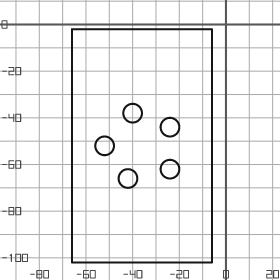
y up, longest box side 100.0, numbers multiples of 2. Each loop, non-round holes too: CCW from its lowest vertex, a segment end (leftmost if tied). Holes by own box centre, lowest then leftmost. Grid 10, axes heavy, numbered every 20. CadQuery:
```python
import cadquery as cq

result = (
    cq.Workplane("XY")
    .moveTo(-66.0, -102.0)
    .lineTo(-6.0, -102.0)
    .lineTo(-6.0, -2.0)
    .lineTo(-66.0, -2.0)
    .close()
    .moveTo(-42.0, -66.0)
    .circle(4.0)
    .moveTo(-24.0, -62.0)
    .circle(4.0)
    .moveTo(-52.0, -52.0)
    .circle(4.0)
    .moveTo(-24.0, -44.0)
    .circle(4.0)
    .moveTo(-40.0, -38.0)
    .circle(4.0)
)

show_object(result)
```